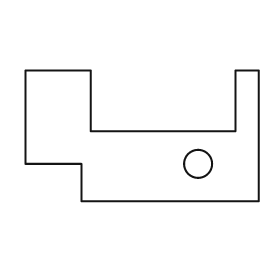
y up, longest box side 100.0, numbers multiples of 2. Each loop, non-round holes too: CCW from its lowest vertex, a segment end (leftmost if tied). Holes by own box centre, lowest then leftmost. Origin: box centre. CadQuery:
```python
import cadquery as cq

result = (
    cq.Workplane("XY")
    .moveTo(-26.0, -28.0)
    .lineTo(50.0, -28.0)
    .lineTo(50.0, 28.0)
    .lineTo(40.0, 28.0)
    .lineTo(40.0, 2.0)
    .lineTo(-22.0, 2.0)
    .lineTo(-22.0, 28.0)
    .lineTo(-50.0, 28.0)
    .lineTo(-50.0, -12.0)
    .lineTo(-26.0, -12.0)
    .close()
    .moveTo(24.0, -12.0)
    .circle(6.0)
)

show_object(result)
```